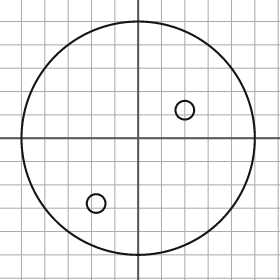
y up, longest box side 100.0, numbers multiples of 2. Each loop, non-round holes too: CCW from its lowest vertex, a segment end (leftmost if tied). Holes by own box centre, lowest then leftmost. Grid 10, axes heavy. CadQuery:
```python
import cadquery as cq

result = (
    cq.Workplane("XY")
    .moveTo(0.0, 0.0)
    .circle(50.0)
    .moveTo(-18.0, -28.0)
    .circle(4.0)
    .moveTo(20.0, 12.0)
    .circle(4.0)
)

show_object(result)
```